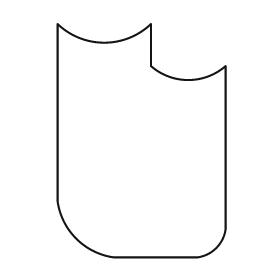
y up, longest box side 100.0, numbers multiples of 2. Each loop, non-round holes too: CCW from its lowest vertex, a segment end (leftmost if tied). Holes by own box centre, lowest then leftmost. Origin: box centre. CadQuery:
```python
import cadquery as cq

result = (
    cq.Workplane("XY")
    .moveTo(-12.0, -50.0)
    .lineTo(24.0, -50.0)
    .threePointArc((32.0, -46.0), (36.0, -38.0))
    .lineTo(36.0, 32.0)
    .threePointArc((20.0, 26.0), (4.0, 32.0))
    .lineTo(4.0, 50.0)
    .threePointArc((-16.0, 42.0), (-36.0, 50.0))
    .lineTo(-36.0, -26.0)
    .threePointArc((-28.0, -42.0), (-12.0, -50.0))
    .close()
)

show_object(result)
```